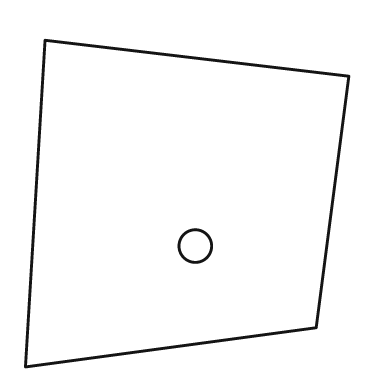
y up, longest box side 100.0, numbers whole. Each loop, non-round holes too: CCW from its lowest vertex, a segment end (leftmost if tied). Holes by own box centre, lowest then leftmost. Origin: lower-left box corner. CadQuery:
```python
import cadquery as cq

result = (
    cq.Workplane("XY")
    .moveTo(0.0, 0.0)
    .lineTo(89.0, 12.0)
    .lineTo(99.0, 89.0)
    .lineTo(6.0, 100.0)
    .close()
    .moveTo(52.0, 37.0)
    .circle(5.0)
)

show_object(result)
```